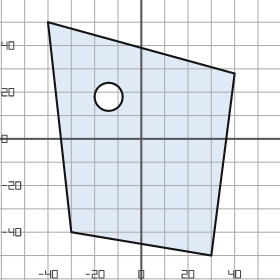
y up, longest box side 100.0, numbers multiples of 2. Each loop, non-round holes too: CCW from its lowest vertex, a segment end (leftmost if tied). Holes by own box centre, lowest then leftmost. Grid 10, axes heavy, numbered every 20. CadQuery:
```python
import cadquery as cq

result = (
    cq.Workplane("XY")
    .moveTo(30.0, -50.0)
    .lineTo(40.0, 28.0)
    .lineTo(-40.0, 50.0)
    .lineTo(-30.0, -40.0)
    .close()
    .moveTo(-14.0, 18.0)
    .circle(6.0)
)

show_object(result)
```